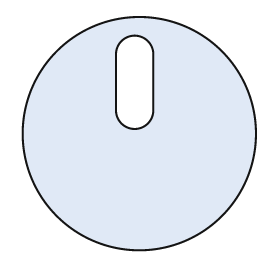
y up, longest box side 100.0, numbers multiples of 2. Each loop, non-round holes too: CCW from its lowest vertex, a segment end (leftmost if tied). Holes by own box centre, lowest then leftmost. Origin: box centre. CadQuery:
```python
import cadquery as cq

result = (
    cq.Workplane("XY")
    .moveTo(0.0, 0.0)
    .circle(50.0)
    .moveTo(-10.0, 10.0)
    .threePointArc((-2.0, 2.0), (6.0, 10.0))
    .lineTo(6.0, 34.0)
    .threePointArc((-2.0, 42.0), (-10.0, 34.0))
    .close()
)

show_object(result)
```